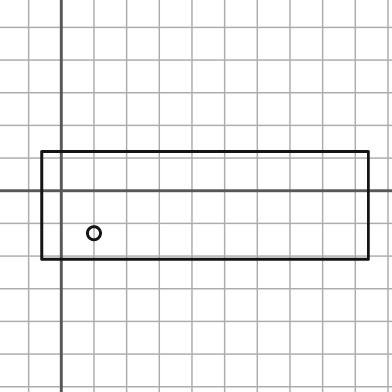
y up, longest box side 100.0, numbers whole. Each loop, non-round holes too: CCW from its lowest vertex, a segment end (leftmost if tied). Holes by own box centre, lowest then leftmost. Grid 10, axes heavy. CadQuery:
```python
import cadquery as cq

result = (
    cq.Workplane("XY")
    .moveTo(-6.0, -21.0)
    .lineTo(94.0, -21.0)
    .lineTo(94.0, 12.0)
    .lineTo(-6.0, 12.0)
    .close()
    .moveTo(10.0, -13.0)
    .circle(2.0)
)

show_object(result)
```